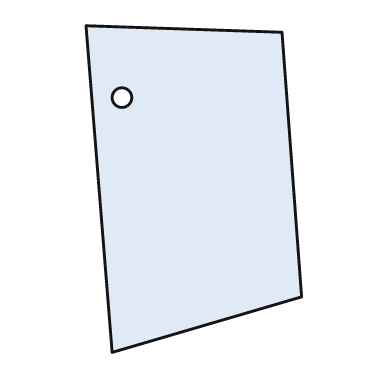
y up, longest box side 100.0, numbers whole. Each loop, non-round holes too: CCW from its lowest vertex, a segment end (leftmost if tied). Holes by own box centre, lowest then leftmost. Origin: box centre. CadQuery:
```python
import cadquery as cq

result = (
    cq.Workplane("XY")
    .moveTo(-25.0, -50.0)
    .lineTo(33.0, -33.0)
    .lineTo(27.0, 48.0)
    .lineTo(-33.0, 50.0)
    .close()
    .moveTo(-22.0, 28.0)
    .circle(3.0)
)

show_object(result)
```